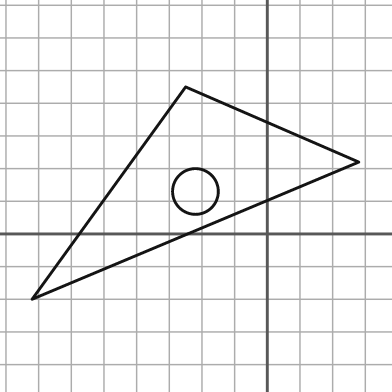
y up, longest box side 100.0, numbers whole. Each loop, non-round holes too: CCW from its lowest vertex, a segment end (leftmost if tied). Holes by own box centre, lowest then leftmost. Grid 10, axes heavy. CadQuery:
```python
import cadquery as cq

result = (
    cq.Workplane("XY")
    .moveTo(-72.0, -20.0)
    .lineTo(28.0, 22.0)
    .lineTo(-25.0, 45.0)
    .close()
    .moveTo(-22.0, 13.0)
    .circle(7.0)
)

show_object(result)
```